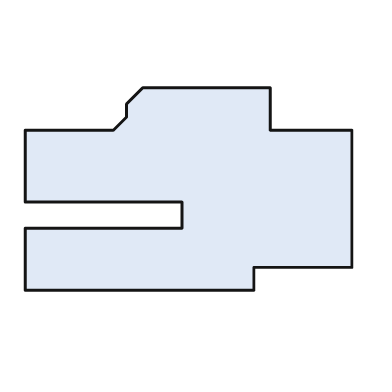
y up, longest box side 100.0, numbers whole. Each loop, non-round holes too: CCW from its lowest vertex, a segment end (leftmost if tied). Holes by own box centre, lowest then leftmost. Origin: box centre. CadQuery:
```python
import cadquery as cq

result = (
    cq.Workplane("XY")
    .moveTo(-50.0, -31.0)
    .lineTo(20.0, -31.0)
    .lineTo(20.0, -24.0)
    .lineTo(50.0, -24.0)
    .lineTo(50.0, 18.0)
    .lineTo(25.0, 18.0)
    .lineTo(25.0, 31.0)
    .lineTo(-14.0, 31.0)
    .lineTo(-19.0, 26.0)
    .lineTo(-19.0, 22.0)
    .lineTo(-23.0, 18.0)
    .lineTo(-50.0, 18.0)
    .lineTo(-50.0, -4.0)
    .lineTo(-2.0, -4.0)
    .lineTo(-2.0, -12.0)
    .lineTo(-50.0, -12.0)
    .close()
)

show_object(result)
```